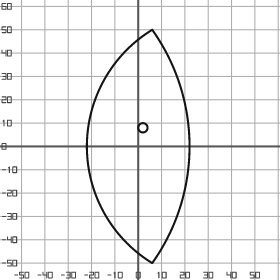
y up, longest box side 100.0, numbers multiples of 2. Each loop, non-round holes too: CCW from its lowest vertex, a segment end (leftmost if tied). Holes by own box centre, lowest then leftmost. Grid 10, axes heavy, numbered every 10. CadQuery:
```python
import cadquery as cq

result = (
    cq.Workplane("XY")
    .moveTo(6.0, -50.0)
    .threePointArc((22.0, 0.0), (6.0, 50.0))
    .threePointArc((-22.0, 0.0), (6.0, -50.0))
    .close()
    .moveTo(2.0, 8.0)
    .circle(2.0)
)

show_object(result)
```